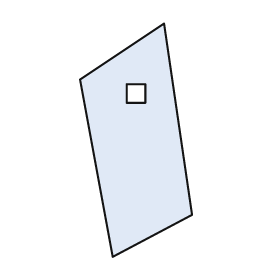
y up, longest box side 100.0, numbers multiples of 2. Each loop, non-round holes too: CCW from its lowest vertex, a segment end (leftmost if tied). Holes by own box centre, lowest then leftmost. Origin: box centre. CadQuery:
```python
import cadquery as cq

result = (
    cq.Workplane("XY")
    .moveTo(-10.0, -50.0)
    .lineTo(24.0, -32.0)
    .lineTo(12.0, 50.0)
    .lineTo(-24.0, 26.0)
    .close()
    .moveTo(-4.0, 16.0)
    .lineTo(4.0, 16.0)
    .lineTo(4.0, 24.0)
    .lineTo(-4.0, 24.0)
    .close()
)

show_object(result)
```